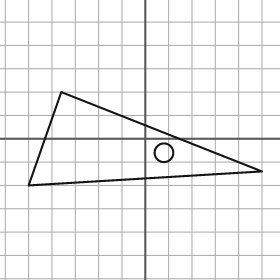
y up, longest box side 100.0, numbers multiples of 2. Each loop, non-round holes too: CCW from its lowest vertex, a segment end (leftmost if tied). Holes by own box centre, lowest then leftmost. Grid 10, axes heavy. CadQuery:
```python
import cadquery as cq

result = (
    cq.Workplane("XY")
    .moveTo(-50.0, -20.0)
    .lineTo(50.0, -14.0)
    .lineTo(-36.0, 20.0)
    .close()
    .moveTo(8.0, -6.0)
    .circle(4.0)
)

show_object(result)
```